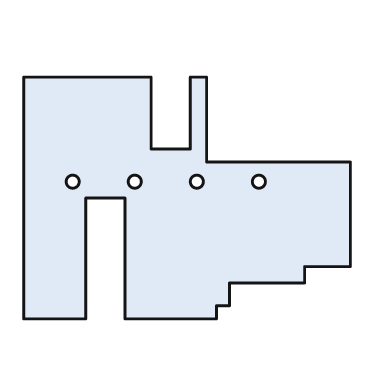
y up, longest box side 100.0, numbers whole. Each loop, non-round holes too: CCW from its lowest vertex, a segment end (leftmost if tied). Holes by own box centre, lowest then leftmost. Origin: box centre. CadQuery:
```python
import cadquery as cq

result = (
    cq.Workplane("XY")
    .moveTo(-50.0, -37.0)
    .lineTo(-31.0, -37.0)
    .lineTo(-31.0, 0.0)
    .lineTo(-19.0, 0.0)
    .lineTo(-19.0, -37.0)
    .lineTo(9.0, -37.0)
    .lineTo(9.0, -33.0)
    .lineTo(13.0, -33.0)
    .lineTo(13.0, -26.0)
    .lineTo(36.0, -26.0)
    .lineTo(36.0, -21.0)
    .lineTo(50.0, -21.0)
    .lineTo(50.0, 11.0)
    .lineTo(6.0, 11.0)
    .lineTo(6.0, 37.0)
    .lineTo(1.0, 37.0)
    .lineTo(1.0, 15.0)
    .lineTo(-11.0, 15.0)
    .lineTo(-11.0, 37.0)
    .lineTo(-50.0, 37.0)
    .close()
    .moveTo(-35.0, 5.0)
    .circle(2.0)
    .moveTo(-16.0, 5.0)
    .circle(2.0)
    .moveTo(3.0, 5.0)
    .circle(2.0)
    .moveTo(22.0, 5.0)
    .circle(2.0)
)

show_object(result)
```